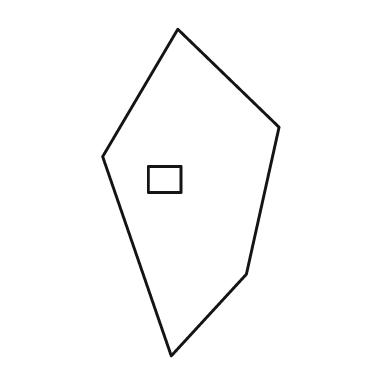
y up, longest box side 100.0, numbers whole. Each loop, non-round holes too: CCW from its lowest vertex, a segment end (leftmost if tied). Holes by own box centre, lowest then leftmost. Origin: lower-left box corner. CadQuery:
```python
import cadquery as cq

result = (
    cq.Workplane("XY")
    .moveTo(21.0, 0.0)
    .lineTo(44.0, 25.0)
    .lineTo(54.0, 70.0)
    .lineTo(23.0, 100.0)
    .lineTo(0.0, 61.0)
    .close()
    .moveTo(14.0, 50.0)
    .lineTo(24.0, 50.0)
    .lineTo(24.0, 58.0)
    .lineTo(14.0, 58.0)
    .close()
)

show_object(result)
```